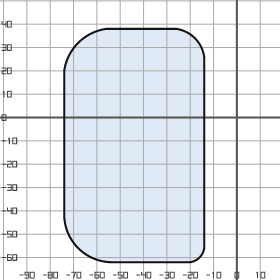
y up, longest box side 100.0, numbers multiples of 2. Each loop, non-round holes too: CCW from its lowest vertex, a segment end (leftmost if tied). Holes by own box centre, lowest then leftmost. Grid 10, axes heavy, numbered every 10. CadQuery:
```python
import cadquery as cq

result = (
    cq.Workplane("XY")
    .moveTo(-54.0, -62.0)
    .lineTo(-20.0, -62.0)
    .threePointArc((-16.0, -60.0), (-14.0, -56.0))
    .lineTo(-14.0, 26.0)
    .threePointArc((-18.0, 34.0), (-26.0, 38.0))
    .lineTo(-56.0, 38.0)
    .threePointArc((-68.0, 32.0), (-74.0, 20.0))
    .lineTo(-74.0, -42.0)
    .threePointArc((-68.0, -56.0), (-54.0, -62.0))
    .close()
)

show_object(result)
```